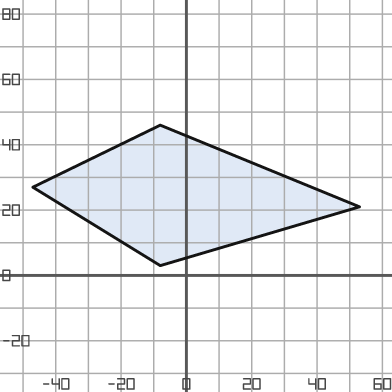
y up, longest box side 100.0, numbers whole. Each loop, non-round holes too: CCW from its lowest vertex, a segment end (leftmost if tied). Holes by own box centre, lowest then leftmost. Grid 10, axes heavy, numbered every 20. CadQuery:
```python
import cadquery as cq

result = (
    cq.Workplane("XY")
    .moveTo(-8.0, 3.0)
    .lineTo(53.0, 21.0)
    .lineTo(-8.0, 46.0)
    .lineTo(-47.0, 27.0)
    .close()
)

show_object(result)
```